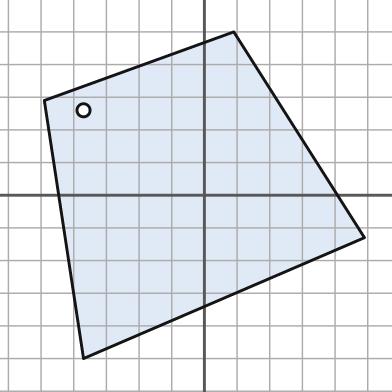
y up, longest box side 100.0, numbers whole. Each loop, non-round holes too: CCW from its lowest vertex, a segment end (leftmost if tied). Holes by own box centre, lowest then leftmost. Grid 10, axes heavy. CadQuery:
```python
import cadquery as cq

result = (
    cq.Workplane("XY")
    .moveTo(-37.0, -50.0)
    .lineTo(49.0, -13.0)
    .lineTo(9.0, 50.0)
    .lineTo(-49.0, 29.0)
    .close()
    .moveTo(-37.0, 26.0)
    .circle(2.0)
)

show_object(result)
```